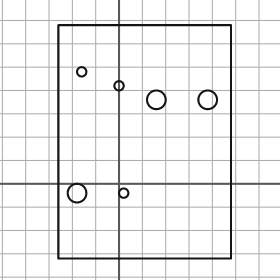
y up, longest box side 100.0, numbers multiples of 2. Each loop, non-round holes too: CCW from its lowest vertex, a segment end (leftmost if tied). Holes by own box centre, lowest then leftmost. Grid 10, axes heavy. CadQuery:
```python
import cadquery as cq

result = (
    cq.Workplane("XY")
    .moveTo(-26.0, -32.0)
    .lineTo(48.0, -32.0)
    .lineTo(48.0, 68.0)
    .lineTo(-26.0, 68.0)
    .close()
    .moveTo(-18.0, -4.0)
    .circle(4.0)
    .moveTo(2.0, -4.0)
    .circle(2.0)
    .moveTo(16.0, 36.0)
    .circle(4.0)
    .moveTo(38.0, 36.0)
    .circle(4.0)
    .moveTo(0.0, 42.0)
    .circle(2.0)
    .moveTo(-16.0, 48.0)
    .circle(2.0)
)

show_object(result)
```